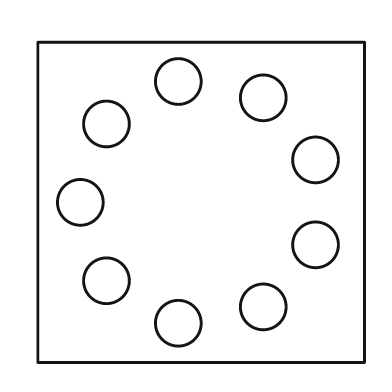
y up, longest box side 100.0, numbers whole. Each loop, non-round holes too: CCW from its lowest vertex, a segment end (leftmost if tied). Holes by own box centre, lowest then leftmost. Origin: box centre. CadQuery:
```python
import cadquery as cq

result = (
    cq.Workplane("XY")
    .moveTo(-50.0, -49.0)
    .lineTo(50.0, -49.0)
    .lineTo(50.0, 49.0)
    .lineTo(-50.0, 49.0)
    .close()
    .moveTo(-7.0, -37.0)
    .circle(7.0)
    .moveTo(19.0, -32.0)
    .circle(7.0)
    .moveTo(-29.0, -24.0)
    .circle(7.0)
    .moveTo(35.0, -13.0)
    .circle(7.0)
    .moveTo(-37.0, 0.0)
    .circle(7.0)
    .moveTo(35.0, 13.0)
    .circle(7.0)
    .moveTo(-29.0, 24.0)
    .circle(7.0)
    .moveTo(19.0, 32.0)
    .circle(7.0)
    .moveTo(-7.0, 37.0)
    .circle(7.0)
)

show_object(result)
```